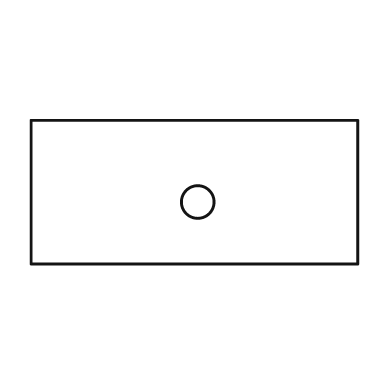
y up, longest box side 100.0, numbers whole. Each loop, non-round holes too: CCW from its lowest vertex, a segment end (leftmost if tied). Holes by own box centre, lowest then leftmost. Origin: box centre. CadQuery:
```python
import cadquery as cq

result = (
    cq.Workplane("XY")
    .moveTo(-50.0, -22.0)
    .lineTo(50.0, -22.0)
    .lineTo(50.0, 22.0)
    .lineTo(-50.0, 22.0)
    .close()
    .moveTo(1.0, -3.0)
    .circle(5.0)
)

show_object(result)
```